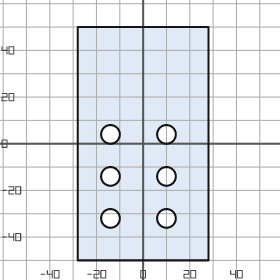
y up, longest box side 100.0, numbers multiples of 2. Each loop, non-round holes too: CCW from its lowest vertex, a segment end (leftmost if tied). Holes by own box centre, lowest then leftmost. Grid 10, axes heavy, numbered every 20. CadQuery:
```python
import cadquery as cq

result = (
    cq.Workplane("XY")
    .moveTo(-28.0, -50.0)
    .lineTo(28.0, -50.0)
    .lineTo(28.0, 50.0)
    .lineTo(-28.0, 50.0)
    .close()
    .moveTo(-14.0, -32.0)
    .circle(4.0)
    .moveTo(10.0, -32.0)
    .circle(4.0)
    .moveTo(-14.0, -14.0)
    .circle(4.0)
    .moveTo(10.0, -14.0)
    .circle(4.0)
    .moveTo(-14.0, 4.0)
    .circle(4.0)
    .moveTo(10.0, 4.0)
    .circle(4.0)
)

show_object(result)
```